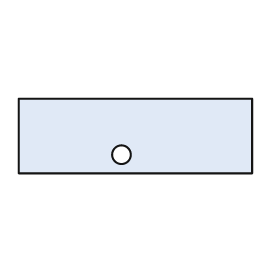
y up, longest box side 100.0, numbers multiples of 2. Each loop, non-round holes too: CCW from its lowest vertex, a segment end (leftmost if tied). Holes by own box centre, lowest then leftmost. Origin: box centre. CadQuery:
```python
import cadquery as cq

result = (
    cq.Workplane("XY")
    .moveTo(-50.0, -16.0)
    .lineTo(50.0, -16.0)
    .lineTo(50.0, 16.0)
    .lineTo(-50.0, 16.0)
    .close()
    .moveTo(-6.0, -8.0)
    .circle(4.0)
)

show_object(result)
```